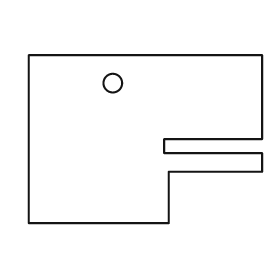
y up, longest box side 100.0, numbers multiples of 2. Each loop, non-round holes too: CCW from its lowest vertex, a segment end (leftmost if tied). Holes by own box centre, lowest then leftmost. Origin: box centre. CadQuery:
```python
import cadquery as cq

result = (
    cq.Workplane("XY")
    .moveTo(-50.0, -36.0)
    .lineTo(10.0, -36.0)
    .lineTo(10.0, -14.0)
    .lineTo(50.0, -14.0)
    .lineTo(50.0, -6.0)
    .lineTo(8.0, -6.0)
    .lineTo(8.0, 0.0)
    .lineTo(50.0, 0.0)
    .lineTo(50.0, 36.0)
    .lineTo(-50.0, 36.0)
    .close()
    .moveTo(-14.0, 24.0)
    .circle(4.0)
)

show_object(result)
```